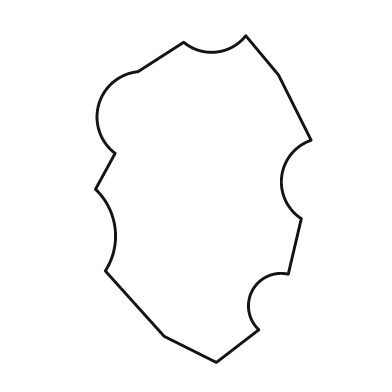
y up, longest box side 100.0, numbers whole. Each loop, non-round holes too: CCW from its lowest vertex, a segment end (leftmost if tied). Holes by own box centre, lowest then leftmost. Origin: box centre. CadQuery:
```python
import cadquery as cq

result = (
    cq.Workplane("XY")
    .moveTo(4.0, -50.0)
    .lineTo(17.0, -40.0)
    .threePointArc((15.0, -28.0), (26.0, -23.0))
    .lineTo(30.0, -6.0)
    .threePointArc((24.0, 7.0), (33.0, 18.0))
    .lineTo(23.0, 38.0)
    .lineTo(13.0, 50.0)
    .threePointArc((4.0, 45.0), (-6.0, 48.0))
    .lineTo(-20.0, 39.0)
    .threePointArc((-32.0, 29.0), (-27.0, 14.0))
    .lineTo(-33.0, 3.0)
    .threePointArc((-27.0, -9.0), (-30.0, -22.0))
    .lineTo(-12.0, -42.0)
    .close()
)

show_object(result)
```